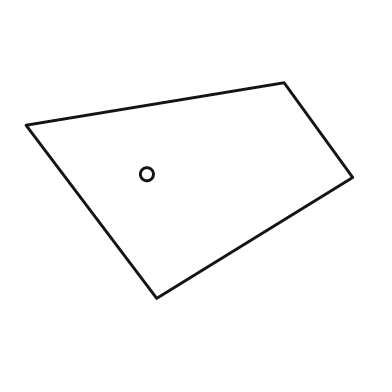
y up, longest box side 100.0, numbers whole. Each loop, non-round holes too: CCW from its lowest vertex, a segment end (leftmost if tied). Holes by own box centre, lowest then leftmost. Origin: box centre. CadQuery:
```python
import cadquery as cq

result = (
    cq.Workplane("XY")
    .moveTo(-10.0, -33.0)
    .lineTo(50.0, 4.0)
    .lineTo(29.0, 33.0)
    .lineTo(-50.0, 20.0)
    .close()
    .moveTo(-13.0, 5.0)
    .circle(2.0)
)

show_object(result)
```